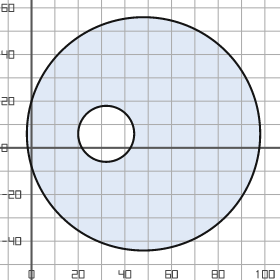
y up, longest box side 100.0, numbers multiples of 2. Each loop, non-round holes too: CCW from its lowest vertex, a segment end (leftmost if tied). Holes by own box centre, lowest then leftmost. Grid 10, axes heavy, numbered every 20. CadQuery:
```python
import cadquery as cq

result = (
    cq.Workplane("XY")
    .moveTo(48.0, 6.0)
    .circle(50.0)
    .moveTo(32.0, 6.0)
    .circle(12.0)
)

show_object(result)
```